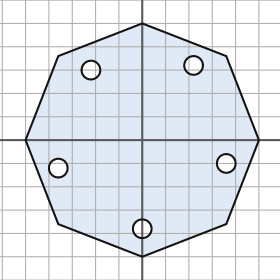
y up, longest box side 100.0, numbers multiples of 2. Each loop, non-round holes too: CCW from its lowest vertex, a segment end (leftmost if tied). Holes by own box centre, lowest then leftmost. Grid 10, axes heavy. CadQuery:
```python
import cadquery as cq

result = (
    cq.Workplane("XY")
    .moveTo(0.0, -50.0)
    .lineTo(36.0, -36.0)
    .lineTo(50.0, 0.0)
    .lineTo(36.0, 36.0)
    .lineTo(0.0, 50.0)
    .lineTo(-36.0, 36.0)
    .lineTo(-50.0, 0.0)
    .lineTo(-36.0, -36.0)
    .close()
    .moveTo(0.0, -38.0)
    .circle(4.0)
    .moveTo(-36.0, -12.0)
    .circle(4.0)
    .moveTo(36.0, -10.0)
    .circle(4.0)
    .moveTo(-22.0, 30.0)
    .circle(4.0)
    .moveTo(22.0, 32.0)
    .circle(4.0)
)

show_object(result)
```